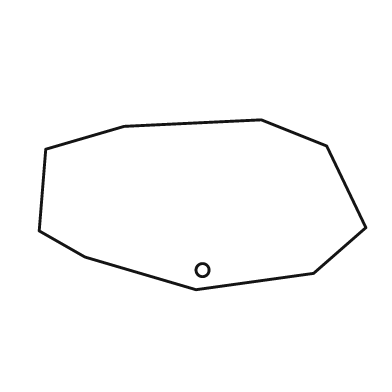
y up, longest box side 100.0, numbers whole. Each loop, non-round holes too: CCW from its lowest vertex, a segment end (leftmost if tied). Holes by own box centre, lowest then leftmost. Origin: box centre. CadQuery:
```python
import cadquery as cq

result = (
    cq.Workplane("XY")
    .moveTo(-2.0, -26.0)
    .lineTo(34.0, -21.0)
    .lineTo(50.0, -7.0)
    .lineTo(38.0, 18.0)
    .lineTo(18.0, 26.0)
    .lineTo(-24.0, 24.0)
    .lineTo(-48.0, 17.0)
    .lineTo(-50.0, -8.0)
    .lineTo(-36.0, -16.0)
    .close()
    .moveTo(0.0, -20.0)
    .circle(2.0)
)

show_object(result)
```